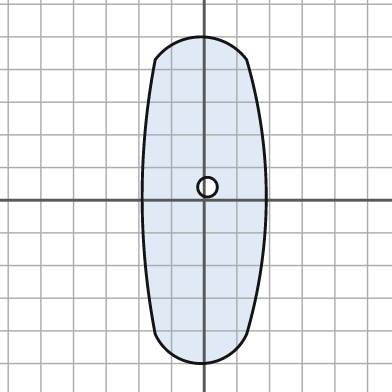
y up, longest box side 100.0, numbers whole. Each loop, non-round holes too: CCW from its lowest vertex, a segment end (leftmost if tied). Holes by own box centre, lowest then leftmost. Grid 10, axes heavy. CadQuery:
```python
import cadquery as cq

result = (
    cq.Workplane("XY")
    .moveTo(-15.0, -41.0)
    .threePointArc((-1.0, -50.0), (13.0, -41.0))
    .threePointArc((19.0, 1.0), (13.0, 43.0))
    .threePointArc((-1.0, 50.0), (-15.0, 43.0))
    .threePointArc((-19.0, 1.0), (-15.0, -41.0))
    .close()
    .moveTo(1.0, 4.0)
    .circle(3.0)
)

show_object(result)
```